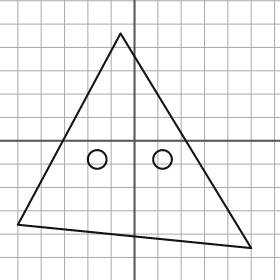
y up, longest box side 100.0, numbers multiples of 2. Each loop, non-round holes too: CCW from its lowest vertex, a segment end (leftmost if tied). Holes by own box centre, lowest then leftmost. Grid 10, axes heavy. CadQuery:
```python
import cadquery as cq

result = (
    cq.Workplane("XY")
    .moveTo(50.0, -46.0)
    .lineTo(-6.0, 46.0)
    .lineTo(-50.0, -36.0)
    .close()
    .moveTo(-16.0, -8.0)
    .circle(4.0)
    .moveTo(12.0, -8.0)
    .circle(4.0)
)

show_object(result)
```